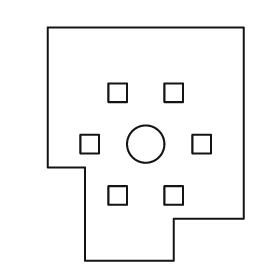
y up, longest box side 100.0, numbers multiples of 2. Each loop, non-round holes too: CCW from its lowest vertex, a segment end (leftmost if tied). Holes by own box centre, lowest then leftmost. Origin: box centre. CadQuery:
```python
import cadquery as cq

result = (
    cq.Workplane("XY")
    .moveTo(-26.0, -50.0)
    .lineTo(12.0, -50.0)
    .lineTo(12.0, -32.0)
    .lineTo(42.0, -32.0)
    .lineTo(42.0, 50.0)
    .lineTo(-42.0, 50.0)
    .lineTo(-42.0, -10.0)
    .lineTo(-26.0, -10.0)
    .close()
    .moveTo(-16.0, -26.0)
    .lineTo(-8.0, -26.0)
    .lineTo(-8.0, -18.0)
    .lineTo(-16.0, -18.0)
    .close()
    .moveTo(8.0, -26.0)
    .lineTo(16.0, -26.0)
    .lineTo(16.0, -18.0)
    .lineTo(8.0, -18.0)
    .close()
    .moveTo(-28.0, -4.0)
    .lineTo(-20.0, -4.0)
    .lineTo(-20.0, 4.0)
    .lineTo(-28.0, 4.0)
    .close()
    .moveTo(0.0, 0.0)
    .circle(8.0)
    .moveTo(20.0, -4.0)
    .lineTo(28.0, -4.0)
    .lineTo(28.0, 4.0)
    .lineTo(20.0, 4.0)
    .close()
    .moveTo(-16.0, 18.0)
    .lineTo(-8.0, 18.0)
    .lineTo(-8.0, 26.0)
    .lineTo(-16.0, 26.0)
    .close()
    .moveTo(8.0, 18.0)
    .lineTo(16.0, 18.0)
    .lineTo(16.0, 26.0)
    .lineTo(8.0, 26.0)
    .close()
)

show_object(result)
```